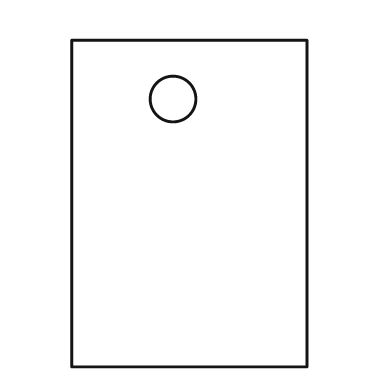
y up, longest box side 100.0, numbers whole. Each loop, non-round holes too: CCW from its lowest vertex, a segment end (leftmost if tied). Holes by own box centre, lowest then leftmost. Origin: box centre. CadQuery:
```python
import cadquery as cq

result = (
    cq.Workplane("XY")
    .moveTo(-36.0, -50.0)
    .lineTo(36.0, -50.0)
    .lineTo(36.0, 50.0)
    .lineTo(-36.0, 50.0)
    .close()
    .moveTo(-5.0, 32.0)
    .circle(7.0)
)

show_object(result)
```